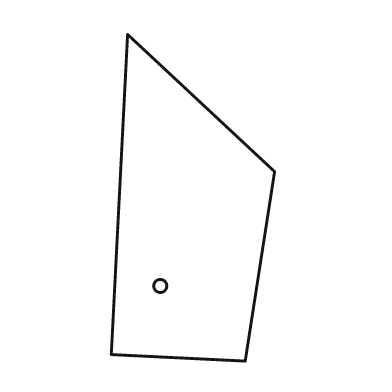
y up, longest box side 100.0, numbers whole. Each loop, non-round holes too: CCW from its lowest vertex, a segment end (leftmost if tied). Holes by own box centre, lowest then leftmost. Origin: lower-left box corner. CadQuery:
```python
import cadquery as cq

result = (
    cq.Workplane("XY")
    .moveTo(41.0, 0.0)
    .lineTo(50.0, 58.0)
    .lineTo(5.0, 100.0)
    .lineTo(0.0, 2.0)
    .close()
    .moveTo(15.0, 23.0)
    .circle(2.0)
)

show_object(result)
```